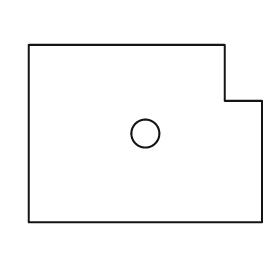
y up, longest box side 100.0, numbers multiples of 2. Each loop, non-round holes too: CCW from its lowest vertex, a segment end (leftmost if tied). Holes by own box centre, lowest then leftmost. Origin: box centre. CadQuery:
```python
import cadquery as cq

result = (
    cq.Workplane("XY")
    .moveTo(-50.0, -38.0)
    .lineTo(50.0, -38.0)
    .lineTo(50.0, 14.0)
    .lineTo(34.0, 14.0)
    .lineTo(34.0, 38.0)
    .lineTo(-50.0, 38.0)
    .close()
    .moveTo(0.0, 0.0)
    .circle(6.0)
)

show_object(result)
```